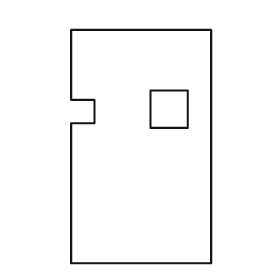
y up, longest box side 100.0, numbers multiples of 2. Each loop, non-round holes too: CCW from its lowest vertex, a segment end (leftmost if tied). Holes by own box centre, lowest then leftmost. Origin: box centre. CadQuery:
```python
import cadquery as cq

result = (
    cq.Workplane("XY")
    .moveTo(-30.0, -50.0)
    .lineTo(30.0, -50.0)
    .lineTo(30.0, 50.0)
    .lineTo(-30.0, 50.0)
    .lineTo(-30.0, 20.0)
    .lineTo(-20.0, 20.0)
    .lineTo(-20.0, 10.0)
    .lineTo(-30.0, 10.0)
    .close()
    .moveTo(4.0, 8.0)
    .lineTo(20.0, 8.0)
    .lineTo(20.0, 24.0)
    .lineTo(4.0, 24.0)
    .close()
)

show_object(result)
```